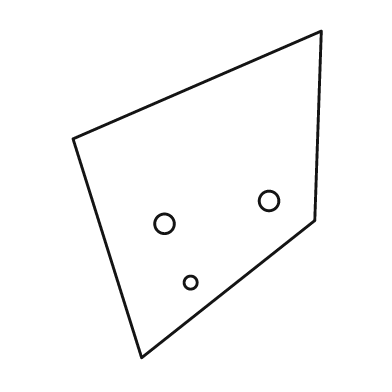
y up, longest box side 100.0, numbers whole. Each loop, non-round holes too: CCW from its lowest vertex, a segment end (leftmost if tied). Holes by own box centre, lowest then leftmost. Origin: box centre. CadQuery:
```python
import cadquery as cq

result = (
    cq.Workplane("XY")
    .moveTo(-17.0, -50.0)
    .lineTo(36.0, -8.0)
    .lineTo(38.0, 50.0)
    .lineTo(-38.0, 17.0)
    .close()
    .moveTo(-2.0, -27.0)
    .circle(2.0)
    .moveTo(-10.0, -9.0)
    .circle(3.0)
    .moveTo(22.0, -2.0)
    .circle(3.0)
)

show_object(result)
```